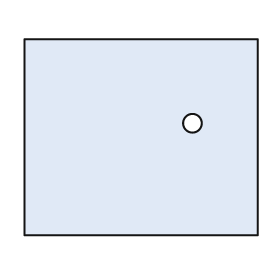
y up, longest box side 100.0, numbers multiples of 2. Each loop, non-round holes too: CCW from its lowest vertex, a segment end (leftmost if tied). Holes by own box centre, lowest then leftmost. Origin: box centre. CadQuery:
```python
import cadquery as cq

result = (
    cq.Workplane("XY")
    .moveTo(-50.0, -42.0)
    .lineTo(50.0, -42.0)
    .lineTo(50.0, 42.0)
    .lineTo(-50.0, 42.0)
    .close()
    .moveTo(22.0, 6.0)
    .circle(4.0)
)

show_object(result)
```